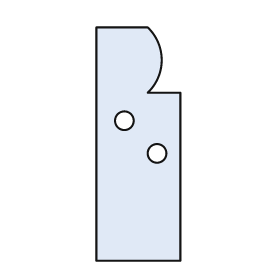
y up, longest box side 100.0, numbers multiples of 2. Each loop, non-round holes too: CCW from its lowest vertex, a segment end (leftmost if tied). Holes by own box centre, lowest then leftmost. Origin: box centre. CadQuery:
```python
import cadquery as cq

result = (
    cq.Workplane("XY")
    .moveTo(-18.0, -50.0)
    .lineTo(18.0, -50.0)
    .lineTo(18.0, 22.0)
    .lineTo(4.0, 22.0)
    .threePointArc((10.0, 36.0), (4.0, 50.0))
    .lineTo(-18.0, 50.0)
    .close()
    .moveTo(8.0, -4.0)
    .circle(4.0)
    .moveTo(-6.0, 10.0)
    .circle(4.0)
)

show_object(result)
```